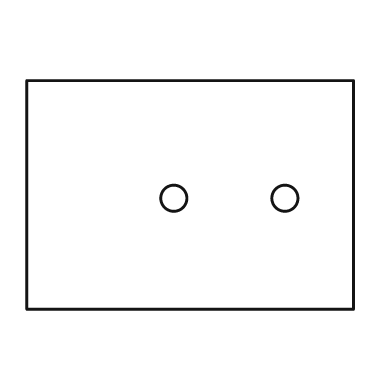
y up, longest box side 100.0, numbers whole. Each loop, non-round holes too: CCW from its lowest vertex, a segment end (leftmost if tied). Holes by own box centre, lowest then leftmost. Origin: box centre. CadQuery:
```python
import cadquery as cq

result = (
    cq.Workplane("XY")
    .moveTo(-50.0, -35.0)
    .lineTo(50.0, -35.0)
    .lineTo(50.0, 35.0)
    .lineTo(-50.0, 35.0)
    .close()
    .moveTo(-5.0, -1.0)
    .circle(4.0)
    .moveTo(29.0, -1.0)
    .circle(4.0)
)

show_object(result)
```